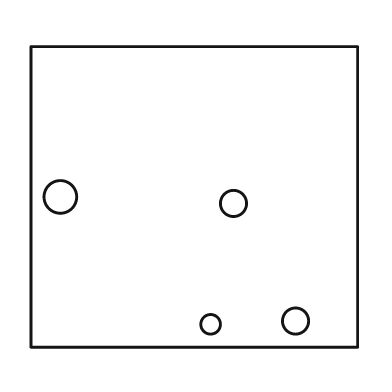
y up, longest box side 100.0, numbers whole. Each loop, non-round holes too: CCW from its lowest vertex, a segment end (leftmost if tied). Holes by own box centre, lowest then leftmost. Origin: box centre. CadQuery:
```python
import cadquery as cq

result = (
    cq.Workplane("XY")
    .moveTo(-50.0, -46.0)
    .lineTo(50.0, -46.0)
    .lineTo(50.0, 46.0)
    .lineTo(-50.0, 46.0)
    .close()
    .moveTo(5.0, -39.0)
    .circle(3.0)
    .moveTo(31.0, -38.0)
    .circle(4.0)
    .moveTo(12.0, -2.0)
    .circle(4.0)
    .moveTo(-41.0, 0.0)
    .circle(5.0)
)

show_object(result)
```